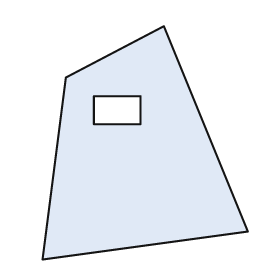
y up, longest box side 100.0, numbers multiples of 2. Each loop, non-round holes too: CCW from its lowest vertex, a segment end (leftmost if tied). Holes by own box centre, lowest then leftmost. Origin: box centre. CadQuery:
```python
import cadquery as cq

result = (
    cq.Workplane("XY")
    .moveTo(-44.0, -50.0)
    .lineTo(44.0, -38.0)
    .lineTo(8.0, 50.0)
    .lineTo(-34.0, 28.0)
    .close()
    .moveTo(-22.0, 8.0)
    .lineTo(-2.0, 8.0)
    .lineTo(-2.0, 20.0)
    .lineTo(-22.0, 20.0)
    .close()
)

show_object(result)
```